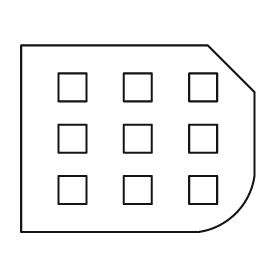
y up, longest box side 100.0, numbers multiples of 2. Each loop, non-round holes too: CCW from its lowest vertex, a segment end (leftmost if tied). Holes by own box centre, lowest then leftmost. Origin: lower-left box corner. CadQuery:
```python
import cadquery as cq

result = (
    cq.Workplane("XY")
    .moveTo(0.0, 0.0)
    .lineTo(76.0, 0.0)
    .threePointArc((92.0, 8.0), (100.0, 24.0))
    .lineTo(100.0, 60.0)
    .lineTo(80.0, 80.0)
    .lineTo(0.0, 80.0)
    .close()
    .moveTo(16.0, 12.0)
    .lineTo(28.0, 12.0)
    .lineTo(28.0, 24.0)
    .lineTo(16.0, 24.0)
    .close()
    .moveTo(44.0, 12.0)
    .lineTo(56.0, 12.0)
    .lineTo(56.0, 24.0)
    .lineTo(44.0, 24.0)
    .close()
    .moveTo(72.0, 12.0)
    .lineTo(84.0, 12.0)
    .lineTo(84.0, 24.0)
    .lineTo(72.0, 24.0)
    .close()
    .moveTo(16.0, 34.0)
    .lineTo(28.0, 34.0)
    .lineTo(28.0, 46.0)
    .lineTo(16.0, 46.0)
    .close()
    .moveTo(44.0, 34.0)
    .lineTo(56.0, 34.0)
    .lineTo(56.0, 46.0)
    .lineTo(44.0, 46.0)
    .close()
    .moveTo(72.0, 34.0)
    .lineTo(84.0, 34.0)
    .lineTo(84.0, 46.0)
    .lineTo(72.0, 46.0)
    .close()
    .moveTo(16.0, 56.0)
    .lineTo(28.0, 56.0)
    .lineTo(28.0, 68.0)
    .lineTo(16.0, 68.0)
    .close()
    .moveTo(44.0, 56.0)
    .lineTo(56.0, 56.0)
    .lineTo(56.0, 68.0)
    .lineTo(44.0, 68.0)
    .close()
    .moveTo(72.0, 56.0)
    .lineTo(84.0, 56.0)
    .lineTo(84.0, 68.0)
    .lineTo(72.0, 68.0)
    .close()
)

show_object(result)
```